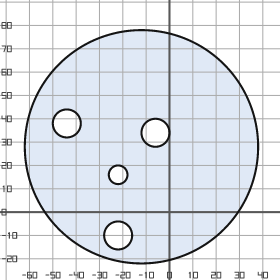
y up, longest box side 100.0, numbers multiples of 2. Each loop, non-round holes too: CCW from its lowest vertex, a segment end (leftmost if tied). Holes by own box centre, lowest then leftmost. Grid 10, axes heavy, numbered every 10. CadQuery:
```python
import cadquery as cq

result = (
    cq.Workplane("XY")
    .moveTo(-12.0, 28.0)
    .circle(50.0)
    .moveTo(-22.0, -10.0)
    .circle(6.0)
    .moveTo(-22.0, 16.0)
    .circle(4.0)
    .moveTo(-6.0, 34.0)
    .circle(6.0)
    .moveTo(-44.0, 38.0)
    .circle(6.0)
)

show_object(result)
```